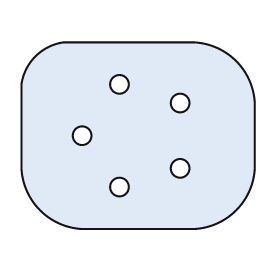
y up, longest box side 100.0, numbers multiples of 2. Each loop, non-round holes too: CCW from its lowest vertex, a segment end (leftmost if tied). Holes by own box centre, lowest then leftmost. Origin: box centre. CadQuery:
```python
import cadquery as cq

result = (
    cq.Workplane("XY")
    .moveTo(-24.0, -40.0)
    .lineTo(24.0, -40.0)
    .threePointArc((42.0, -32.0), (50.0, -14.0))
    .lineTo(50.0, 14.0)
    .threePointArc((42.0, 32.0), (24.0, 40.0))
    .lineTo(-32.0, 40.0)
    .threePointArc((-44.0, 34.0), (-50.0, 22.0))
    .lineTo(-50.0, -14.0)
    .threePointArc((-42.0, -32.0), (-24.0, -40.0))
    .close()
    .moveTo(-8.0, -22.0)
    .circle(4.0)
    .moveTo(18.0, -14.0)
    .circle(4.0)
    .moveTo(-24.0, 0.0)
    .circle(4.0)
    .moveTo(18.0, 14.0)
    .circle(4.0)
    .moveTo(-8.0, 22.0)
    .circle(4.0)
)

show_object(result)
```